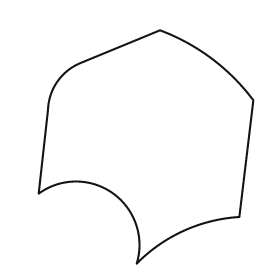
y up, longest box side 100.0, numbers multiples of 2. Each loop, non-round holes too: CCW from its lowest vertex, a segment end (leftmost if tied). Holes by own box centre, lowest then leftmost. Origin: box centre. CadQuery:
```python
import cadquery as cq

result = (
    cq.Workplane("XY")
    .moveTo(-4.0, -50.0)
    .threePointArc((16.0, -36.0), (40.0, -30.0))
    .lineTo(46.0, 20.0)
    .threePointArc((28.0, 38.0), (6.0, 50.0))
    .lineTo(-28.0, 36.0)
    .threePointArc((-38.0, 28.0), (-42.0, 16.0))
    .lineTo(-46.0, -20.0)
    .threePointArc((-14.0, -20.0), (-4.0, -50.0))
    .close()
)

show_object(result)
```